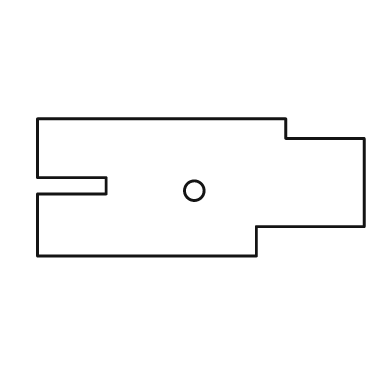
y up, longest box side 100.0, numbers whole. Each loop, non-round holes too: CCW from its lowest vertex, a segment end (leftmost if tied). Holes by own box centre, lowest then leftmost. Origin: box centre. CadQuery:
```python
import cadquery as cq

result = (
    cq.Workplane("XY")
    .moveTo(-50.0, -21.0)
    .lineTo(17.0, -21.0)
    .lineTo(17.0, -12.0)
    .lineTo(50.0, -12.0)
    .lineTo(50.0, 15.0)
    .lineTo(26.0, 15.0)
    .lineTo(26.0, 21.0)
    .lineTo(-50.0, 21.0)
    .lineTo(-50.0, 3.0)
    .lineTo(-29.0, 3.0)
    .lineTo(-29.0, -2.0)
    .lineTo(-50.0, -2.0)
    .close()
    .moveTo(-2.0, -1.0)
    .circle(3.0)
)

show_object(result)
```